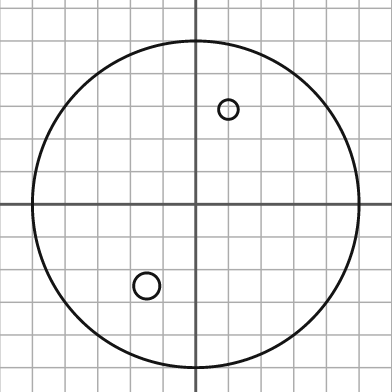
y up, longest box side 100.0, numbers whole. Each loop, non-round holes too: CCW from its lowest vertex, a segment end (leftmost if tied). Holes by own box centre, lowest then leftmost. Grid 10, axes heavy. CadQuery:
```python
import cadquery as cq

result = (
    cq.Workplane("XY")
    .moveTo(0.0, 0.0)
    .circle(50.0)
    .moveTo(-15.0, -25.0)
    .circle(4.0)
    .moveTo(10.0, 29.0)
    .circle(3.0)
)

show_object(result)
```